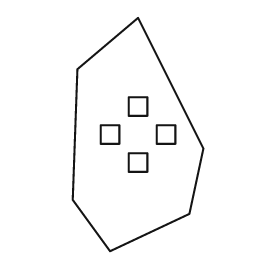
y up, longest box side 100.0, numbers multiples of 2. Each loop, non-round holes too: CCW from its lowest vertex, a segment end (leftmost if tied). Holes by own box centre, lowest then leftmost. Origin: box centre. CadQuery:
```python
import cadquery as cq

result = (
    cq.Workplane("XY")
    .moveTo(-12.0, -50.0)
    .lineTo(22.0, -34.0)
    .lineTo(28.0, -6.0)
    .lineTo(0.0, 50.0)
    .lineTo(-26.0, 28.0)
    .lineTo(-28.0, -28.0)
    .close()
    .moveTo(-4.0, -16.0)
    .lineTo(4.0, -16.0)
    .lineTo(4.0, -8.0)
    .lineTo(-4.0, -8.0)
    .close()
    .moveTo(-16.0, -4.0)
    .lineTo(-8.0, -4.0)
    .lineTo(-8.0, 4.0)
    .lineTo(-16.0, 4.0)
    .close()
    .moveTo(8.0, -4.0)
    .lineTo(16.0, -4.0)
    .lineTo(16.0, 4.0)
    .lineTo(8.0, 4.0)
    .close()
    .moveTo(-4.0, 8.0)
    .lineTo(4.0, 8.0)
    .lineTo(4.0, 16.0)
    .lineTo(-4.0, 16.0)
    .close()
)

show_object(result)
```